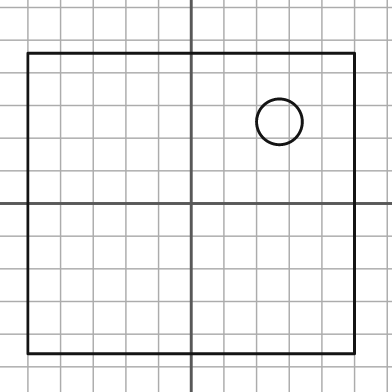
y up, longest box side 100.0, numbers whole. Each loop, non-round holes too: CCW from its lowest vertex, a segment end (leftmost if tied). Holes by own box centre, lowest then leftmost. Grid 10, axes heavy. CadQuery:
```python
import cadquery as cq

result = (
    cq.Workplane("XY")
    .moveTo(-50.0, -46.0)
    .lineTo(50.0, -46.0)
    .lineTo(50.0, 46.0)
    .lineTo(-50.0, 46.0)
    .close()
    .moveTo(27.0, 25.0)
    .circle(7.0)
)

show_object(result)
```